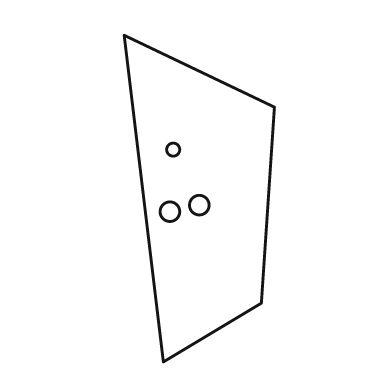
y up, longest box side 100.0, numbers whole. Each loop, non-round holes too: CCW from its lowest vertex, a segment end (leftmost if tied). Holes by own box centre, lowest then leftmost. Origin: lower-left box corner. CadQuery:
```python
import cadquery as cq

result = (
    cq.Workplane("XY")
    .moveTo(12.0, 0.0)
    .lineTo(42.0, 18.0)
    .lineTo(46.0, 78.0)
    .lineTo(0.0, 100.0)
    .close()
    .moveTo(14.0, 46.0)
    .circle(3.0)
    .moveTo(23.0, 48.0)
    .circle(3.0)
    .moveTo(15.0, 65.0)
    .circle(2.0)
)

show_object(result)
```